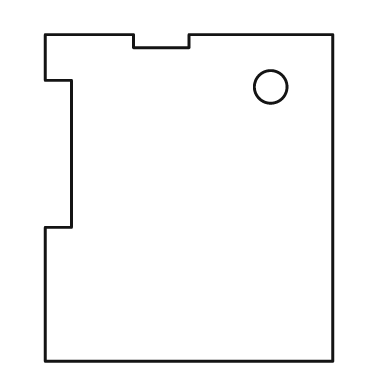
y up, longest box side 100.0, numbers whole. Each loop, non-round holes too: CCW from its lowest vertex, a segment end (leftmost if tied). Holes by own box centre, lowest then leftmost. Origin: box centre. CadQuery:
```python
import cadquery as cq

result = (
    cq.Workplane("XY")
    .moveTo(-44.0, -50.0)
    .lineTo(44.0, -50.0)
    .lineTo(44.0, 50.0)
    .lineTo(0.0, 50.0)
    .lineTo(0.0, 46.0)
    .lineTo(-17.0, 46.0)
    .lineTo(-17.0, 50.0)
    .lineTo(-44.0, 50.0)
    .lineTo(-44.0, 36.0)
    .lineTo(-36.0, 36.0)
    .lineTo(-36.0, -9.0)
    .lineTo(-44.0, -9.0)
    .close()
    .moveTo(25.0, 34.0)
    .circle(5.0)
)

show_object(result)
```